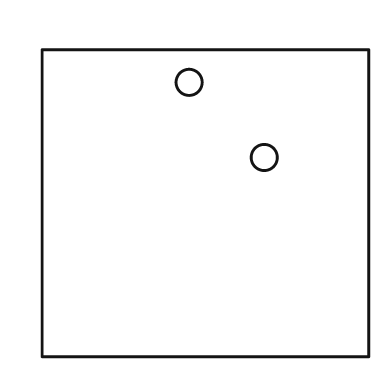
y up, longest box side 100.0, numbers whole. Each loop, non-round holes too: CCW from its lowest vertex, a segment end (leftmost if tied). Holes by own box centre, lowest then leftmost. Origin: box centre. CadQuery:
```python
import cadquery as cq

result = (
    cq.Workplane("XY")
    .moveTo(-50.0, -47.0)
    .lineTo(50.0, -47.0)
    .lineTo(50.0, 47.0)
    .lineTo(-50.0, 47.0)
    .close()
    .moveTo(18.0, 14.0)
    .circle(4.0)
    .moveTo(-5.0, 37.0)
    .circle(4.0)
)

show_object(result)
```